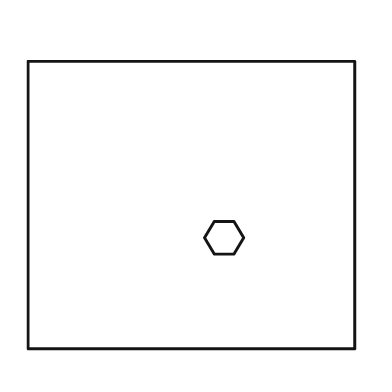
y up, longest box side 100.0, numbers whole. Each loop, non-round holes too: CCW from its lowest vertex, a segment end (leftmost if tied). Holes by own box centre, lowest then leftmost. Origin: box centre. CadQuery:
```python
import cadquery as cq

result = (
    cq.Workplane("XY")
    .moveTo(-50.0, -44.0)
    .lineTo(50.0, -44.0)
    .lineTo(50.0, 44.0)
    .lineTo(-50.0, 44.0)
    .close()
    .moveTo(7.0, -15.0)
    .lineTo(13.0, -15.0)
    .lineTo(16.0, -10.0)
    .lineTo(13.0, -5.0)
    .lineTo(7.0, -5.0)
    .lineTo(4.0, -10.0)
    .close()
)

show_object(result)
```